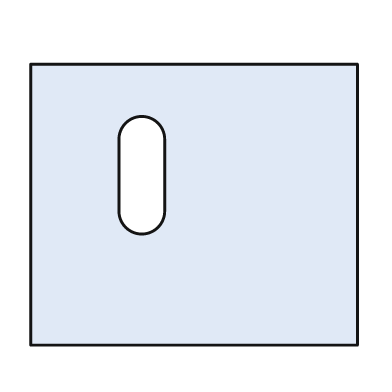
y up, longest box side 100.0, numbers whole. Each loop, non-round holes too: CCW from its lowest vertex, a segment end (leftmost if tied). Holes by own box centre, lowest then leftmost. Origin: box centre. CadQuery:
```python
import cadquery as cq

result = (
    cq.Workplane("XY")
    .moveTo(-50.0, -43.0)
    .lineTo(50.0, -43.0)
    .lineTo(50.0, 43.0)
    .lineTo(-50.0, 43.0)
    .close()
    .moveTo(-23.0, -2.0)
    .threePointArc((-16.0, -9.0), (-9.0, -2.0))
    .lineTo(-9.0, 20.0)
    .threePointArc((-16.0, 27.0), (-23.0, 20.0))
    .close()
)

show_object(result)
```